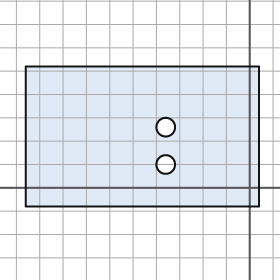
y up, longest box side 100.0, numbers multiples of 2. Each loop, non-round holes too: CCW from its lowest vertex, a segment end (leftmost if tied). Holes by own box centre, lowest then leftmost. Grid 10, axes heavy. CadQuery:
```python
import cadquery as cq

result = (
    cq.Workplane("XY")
    .moveTo(-96.0, -8.0)
    .lineTo(4.0, -8.0)
    .lineTo(4.0, 52.0)
    .lineTo(-96.0, 52.0)
    .close()
    .moveTo(-36.0, 10.0)
    .circle(4.0)
    .moveTo(-36.0, 26.0)
    .circle(4.0)
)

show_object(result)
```